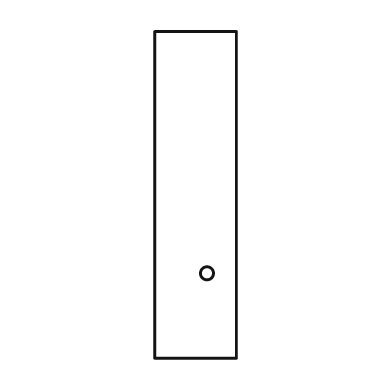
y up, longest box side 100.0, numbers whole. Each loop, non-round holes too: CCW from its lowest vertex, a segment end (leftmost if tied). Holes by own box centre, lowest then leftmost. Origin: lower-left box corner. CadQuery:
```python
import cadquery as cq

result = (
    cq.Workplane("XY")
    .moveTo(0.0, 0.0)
    .lineTo(25.0, 0.0)
    .lineTo(25.0, 100.0)
    .lineTo(0.0, 100.0)
    .close()
    .moveTo(16.0, 26.0)
    .circle(2.0)
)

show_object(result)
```